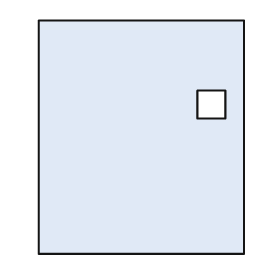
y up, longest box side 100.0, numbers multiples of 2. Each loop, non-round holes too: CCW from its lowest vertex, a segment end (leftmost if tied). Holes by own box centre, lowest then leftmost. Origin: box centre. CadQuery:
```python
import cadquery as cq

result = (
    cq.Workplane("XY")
    .moveTo(-44.0, -50.0)
    .lineTo(44.0, -50.0)
    .lineTo(44.0, 50.0)
    .lineTo(-44.0, 50.0)
    .close()
    .moveTo(24.0, 8.0)
    .lineTo(36.0, 8.0)
    .lineTo(36.0, 20.0)
    .lineTo(24.0, 20.0)
    .close()
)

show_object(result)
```